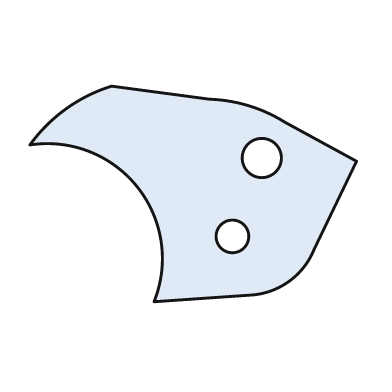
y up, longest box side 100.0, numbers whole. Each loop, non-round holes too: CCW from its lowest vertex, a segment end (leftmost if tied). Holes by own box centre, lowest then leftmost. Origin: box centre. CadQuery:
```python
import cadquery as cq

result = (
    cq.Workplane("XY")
    .moveTo(-12.0, -33.0)
    .lineTo(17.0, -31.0)
    .threePointArc((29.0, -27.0), (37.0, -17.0))
    .lineTo(50.0, 10.0)
    .lineTo(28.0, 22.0)
    .threePointArc((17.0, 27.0), (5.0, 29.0))
    .lineTo(-25.0, 33.0)
    .threePointArc((-39.0, 26.0), (-50.0, 15.0))
    .threePointArc((-17.0, 2.0), (-12.0, -33.0))
    .close()
    .moveTo(12.0, -13.0)
    .circle(5.0)
    .moveTo(21.0, 11.0)
    .circle(6.0)
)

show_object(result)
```